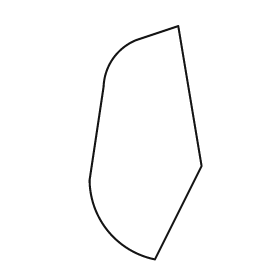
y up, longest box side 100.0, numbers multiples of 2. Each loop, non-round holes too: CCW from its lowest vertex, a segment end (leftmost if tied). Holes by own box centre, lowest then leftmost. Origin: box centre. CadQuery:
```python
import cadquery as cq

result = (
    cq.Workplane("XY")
    .moveTo(4.0, -50.0)
    .lineTo(24.0, -10.0)
    .lineTo(14.0, 50.0)
    .lineTo(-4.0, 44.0)
    .threePointArc((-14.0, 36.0), (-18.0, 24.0))
    .lineTo(-24.0, -16.0)
    .threePointArc((-16.0, -38.0), (4.0, -50.0))
    .close()
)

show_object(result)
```